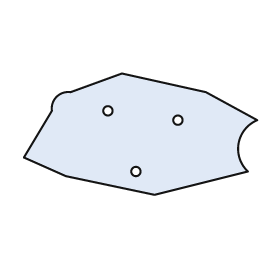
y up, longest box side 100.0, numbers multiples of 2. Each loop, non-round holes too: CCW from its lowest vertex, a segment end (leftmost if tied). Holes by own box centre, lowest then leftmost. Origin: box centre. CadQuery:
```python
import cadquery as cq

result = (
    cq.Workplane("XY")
    .moveTo(6.0, -26.0)
    .lineTo(46.0, -16.0)
    .threePointArc((42.0, -4.0), (50.0, 6.0))
    .lineTo(28.0, 18.0)
    .lineTo(-8.0, 26.0)
    .lineTo(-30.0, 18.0)
    .threePointArc((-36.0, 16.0), (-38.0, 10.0))
    .lineTo(-50.0, -10.0)
    .lineTo(-32.0, -18.0)
    .close()
    .moveTo(-2.0, -16.0)
    .circle(2.0)
    .moveTo(16.0, 6.0)
    .circle(2.0)
    .moveTo(-14.0, 10.0)
    .circle(2.0)
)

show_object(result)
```